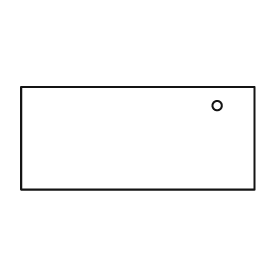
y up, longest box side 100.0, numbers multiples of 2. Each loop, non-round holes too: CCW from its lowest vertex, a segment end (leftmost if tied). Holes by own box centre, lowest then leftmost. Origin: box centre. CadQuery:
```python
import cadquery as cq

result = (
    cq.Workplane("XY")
    .moveTo(-50.0, -22.0)
    .lineTo(50.0, -22.0)
    .lineTo(50.0, 22.0)
    .lineTo(-50.0, 22.0)
    .close()
    .moveTo(34.0, 14.0)
    .circle(2.0)
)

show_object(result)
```